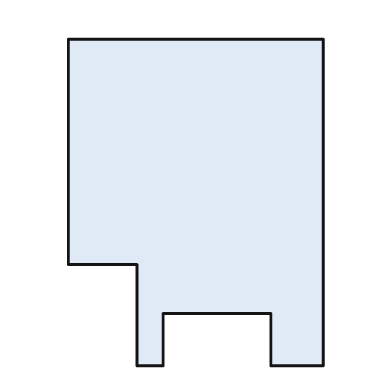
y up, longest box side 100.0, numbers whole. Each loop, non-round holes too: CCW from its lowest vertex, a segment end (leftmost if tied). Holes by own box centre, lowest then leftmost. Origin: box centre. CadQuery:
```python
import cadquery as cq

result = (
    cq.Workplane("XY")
    .moveTo(-18.0, -50.0)
    .lineTo(-10.0, -50.0)
    .lineTo(-10.0, -34.0)
    .lineTo(23.0, -34.0)
    .lineTo(23.0, -50.0)
    .lineTo(39.0, -50.0)
    .lineTo(39.0, 50.0)
    .lineTo(-39.0, 50.0)
    .lineTo(-39.0, -19.0)
    .lineTo(-18.0, -19.0)
    .close()
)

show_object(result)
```